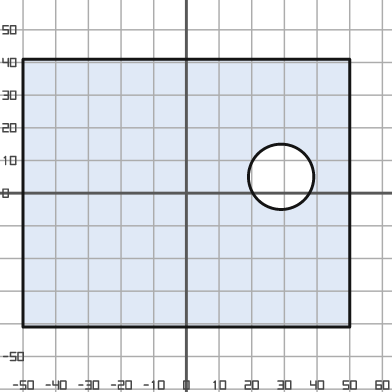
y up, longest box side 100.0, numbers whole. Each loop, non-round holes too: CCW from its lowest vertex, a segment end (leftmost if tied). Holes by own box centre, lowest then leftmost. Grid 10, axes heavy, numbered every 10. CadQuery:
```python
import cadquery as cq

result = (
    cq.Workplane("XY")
    .moveTo(-50.0, -41.0)
    .lineTo(50.0, -41.0)
    .lineTo(50.0, 41.0)
    .lineTo(-50.0, 41.0)
    .close()
    .moveTo(29.0, 5.0)
    .circle(10.0)
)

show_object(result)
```